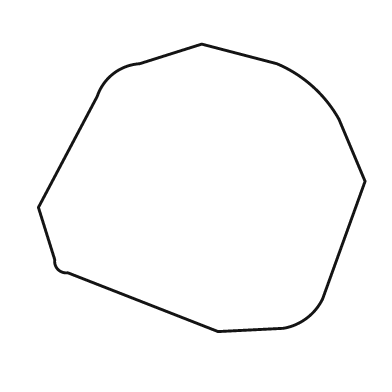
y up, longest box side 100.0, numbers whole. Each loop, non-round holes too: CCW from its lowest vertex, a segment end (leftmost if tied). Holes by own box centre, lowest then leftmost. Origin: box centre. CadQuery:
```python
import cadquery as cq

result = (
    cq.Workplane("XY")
    .moveTo(5.0, -44.0)
    .lineTo(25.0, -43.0)
    .threePointArc((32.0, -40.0), (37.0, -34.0))
    .lineTo(50.0, 2.0)
    .lineTo(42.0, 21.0)
    .threePointArc((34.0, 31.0), (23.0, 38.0))
    .lineTo(0.0, 44.0)
    .lineTo(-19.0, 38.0)
    .threePointArc((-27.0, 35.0), (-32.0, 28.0))
    .lineTo(-50.0, -6.0)
    .lineTo(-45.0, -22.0)
    .threePointArc((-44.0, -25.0), (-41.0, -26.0))
    .close()
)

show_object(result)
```